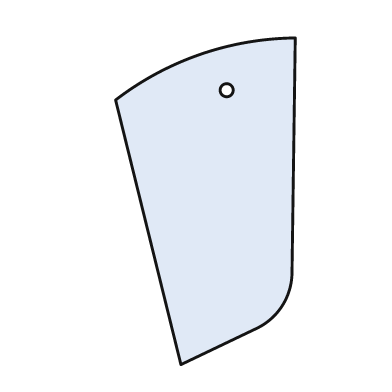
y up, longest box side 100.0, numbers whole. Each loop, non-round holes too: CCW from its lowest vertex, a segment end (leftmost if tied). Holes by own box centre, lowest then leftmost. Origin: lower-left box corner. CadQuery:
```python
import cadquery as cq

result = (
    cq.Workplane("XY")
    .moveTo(20.0, 0.0)
    .lineTo(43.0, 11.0)
    .threePointArc((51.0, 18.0), (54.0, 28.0))
    .lineTo(55.0, 100.0)
    .threePointArc((26.0, 95.0), (0.0, 81.0))
    .close()
    .moveTo(34.0, 84.0)
    .circle(2.0)
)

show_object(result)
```